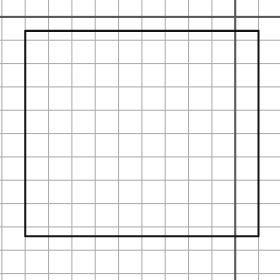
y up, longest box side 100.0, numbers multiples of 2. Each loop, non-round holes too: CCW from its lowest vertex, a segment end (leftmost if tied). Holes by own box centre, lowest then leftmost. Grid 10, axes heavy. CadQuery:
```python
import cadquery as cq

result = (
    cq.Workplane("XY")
    .moveTo(-90.0, -94.0)
    .lineTo(10.0, -94.0)
    .lineTo(10.0, -6.0)
    .lineTo(-90.0, -6.0)
    .close()
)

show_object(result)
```